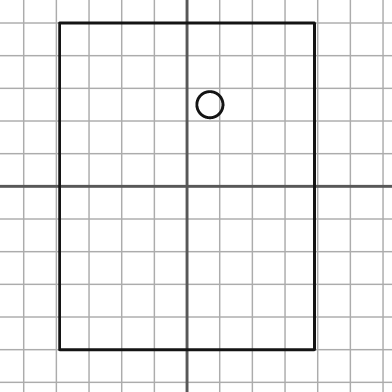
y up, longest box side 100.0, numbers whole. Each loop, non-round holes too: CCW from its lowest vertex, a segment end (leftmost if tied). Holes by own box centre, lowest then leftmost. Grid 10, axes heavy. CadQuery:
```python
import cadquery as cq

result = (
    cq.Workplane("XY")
    .moveTo(-39.0, -50.0)
    .lineTo(39.0, -50.0)
    .lineTo(39.0, 50.0)
    .lineTo(-39.0, 50.0)
    .close()
    .moveTo(7.0, 25.0)
    .circle(4.0)
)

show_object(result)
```